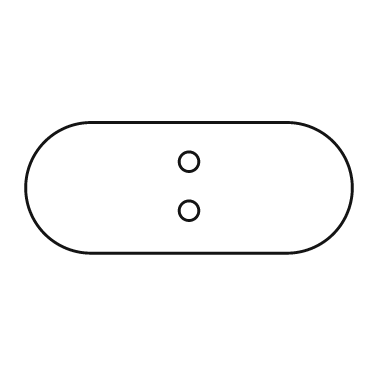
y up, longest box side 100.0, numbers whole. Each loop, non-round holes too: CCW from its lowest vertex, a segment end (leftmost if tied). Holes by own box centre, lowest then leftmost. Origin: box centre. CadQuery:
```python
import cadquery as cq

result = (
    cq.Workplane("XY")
    .moveTo(-30.0, -20.0)
    .lineTo(30.0, -20.0)
    .threePointArc((50.0, 0.0), (30.0, 20.0))
    .lineTo(-30.0, 20.0)
    .threePointArc((-50.0, 0.0), (-30.0, -20.0))
    .close()
    .moveTo(0.0, -7.0)
    .circle(3.0)
    .moveTo(0.0, 8.0)
    .circle(3.0)
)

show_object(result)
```